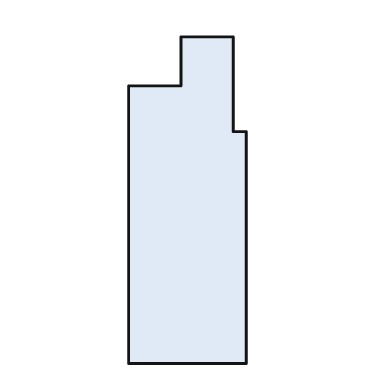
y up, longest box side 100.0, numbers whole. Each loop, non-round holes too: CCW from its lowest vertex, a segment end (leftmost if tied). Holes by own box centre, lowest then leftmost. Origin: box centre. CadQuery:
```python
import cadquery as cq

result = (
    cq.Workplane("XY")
    .moveTo(-18.0, -50.0)
    .lineTo(18.0, -50.0)
    .lineTo(18.0, 21.0)
    .lineTo(14.0, 21.0)
    .lineTo(14.0, 50.0)
    .lineTo(-2.0, 50.0)
    .lineTo(-2.0, 35.0)
    .lineTo(-18.0, 35.0)
    .close()
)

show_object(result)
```